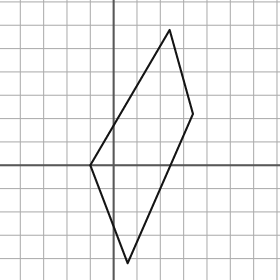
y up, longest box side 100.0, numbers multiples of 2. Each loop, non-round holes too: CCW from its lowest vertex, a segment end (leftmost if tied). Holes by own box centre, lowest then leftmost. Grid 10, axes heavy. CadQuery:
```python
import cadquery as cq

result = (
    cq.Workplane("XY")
    .moveTo(6.0, -42.0)
    .lineTo(34.0, 22.0)
    .lineTo(24.0, 58.0)
    .lineTo(-10.0, 0.0)
    .close()
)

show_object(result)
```